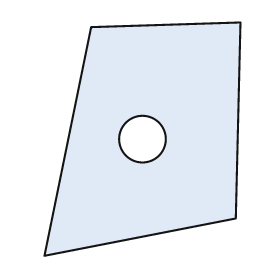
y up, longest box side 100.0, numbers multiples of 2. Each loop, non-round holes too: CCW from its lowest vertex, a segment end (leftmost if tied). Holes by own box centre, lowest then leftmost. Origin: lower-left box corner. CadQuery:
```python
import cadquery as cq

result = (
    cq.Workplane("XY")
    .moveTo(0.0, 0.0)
    .lineTo(82.0, 16.0)
    .lineTo(84.0, 100.0)
    .lineTo(20.0, 98.0)
    .close()
    .moveTo(42.0, 50.0)
    .circle(10.0)
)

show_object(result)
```